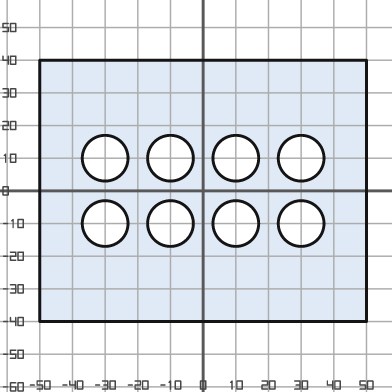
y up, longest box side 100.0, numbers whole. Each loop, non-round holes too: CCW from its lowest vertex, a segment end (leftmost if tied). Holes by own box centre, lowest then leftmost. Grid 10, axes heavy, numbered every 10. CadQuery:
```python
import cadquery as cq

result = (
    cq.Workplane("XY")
    .moveTo(-50.0, -40.0)
    .lineTo(50.0, -40.0)
    .lineTo(50.0, 40.0)
    .lineTo(-50.0, 40.0)
    .close()
    .moveTo(-30.0, -10.0)
    .circle(7.0)
    .moveTo(-10.0, -10.0)
    .circle(7.0)
    .moveTo(10.0, -10.0)
    .circle(7.0)
    .moveTo(30.0, -10.0)
    .circle(7.0)
    .moveTo(-30.0, 10.0)
    .circle(7.0)
    .moveTo(-10.0, 10.0)
    .circle(7.0)
    .moveTo(10.0, 10.0)
    .circle(7.0)
    .moveTo(30.0, 10.0)
    .circle(7.0)
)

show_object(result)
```